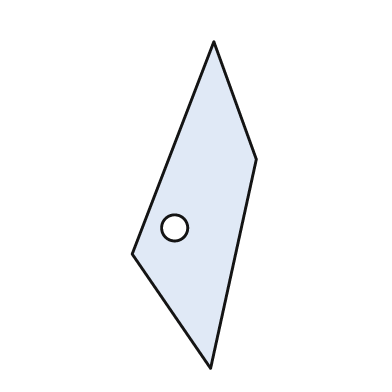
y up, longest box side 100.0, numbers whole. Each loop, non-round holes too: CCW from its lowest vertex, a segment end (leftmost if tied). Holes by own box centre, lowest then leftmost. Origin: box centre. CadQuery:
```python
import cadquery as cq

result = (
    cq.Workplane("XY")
    .moveTo(5.0, -50.0)
    .lineTo(19.0, 14.0)
    .lineTo(6.0, 50.0)
    .lineTo(-19.0, -15.0)
    .close()
    .moveTo(-6.0, -7.0)
    .circle(4.0)
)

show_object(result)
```